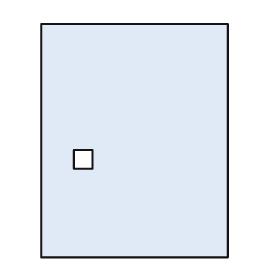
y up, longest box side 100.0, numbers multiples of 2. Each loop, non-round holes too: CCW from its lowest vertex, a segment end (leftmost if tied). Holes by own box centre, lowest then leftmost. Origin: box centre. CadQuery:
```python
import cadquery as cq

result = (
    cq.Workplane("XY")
    .moveTo(-40.0, -50.0)
    .lineTo(40.0, -50.0)
    .lineTo(40.0, 50.0)
    .lineTo(-40.0, 50.0)
    .close()
    .moveTo(-26.0, -12.0)
    .lineTo(-18.0, -12.0)
    .lineTo(-18.0, -4.0)
    .lineTo(-26.0, -4.0)
    .close()
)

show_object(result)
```